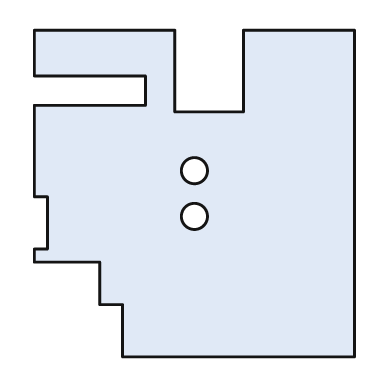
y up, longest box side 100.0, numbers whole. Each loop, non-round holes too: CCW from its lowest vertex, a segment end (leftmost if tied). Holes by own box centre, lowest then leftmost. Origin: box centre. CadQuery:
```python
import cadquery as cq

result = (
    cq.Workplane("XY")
    .moveTo(-22.0, -50.0)
    .lineTo(49.0, -50.0)
    .lineTo(49.0, 50.0)
    .lineTo(15.0, 50.0)
    .lineTo(15.0, 25.0)
    .lineTo(-6.0, 25.0)
    .lineTo(-6.0, 50.0)
    .lineTo(-49.0, 50.0)
    .lineTo(-49.0, 36.0)
    .lineTo(-15.0, 36.0)
    .lineTo(-15.0, 27.0)
    .lineTo(-49.0, 27.0)
    .lineTo(-49.0, -1.0)
    .lineTo(-45.0, -1.0)
    .lineTo(-45.0, -17.0)
    .lineTo(-49.0, -17.0)
    .lineTo(-49.0, -21.0)
    .lineTo(-29.0, -21.0)
    .lineTo(-29.0, -34.0)
    .lineTo(-22.0, -34.0)
    .close()
    .moveTo(0.0, -7.0)
    .circle(4.0)
    .moveTo(0.0, 7.0)
    .circle(4.0)
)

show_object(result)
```